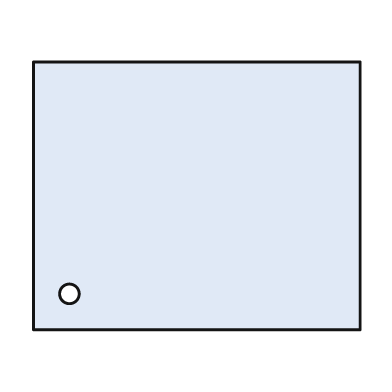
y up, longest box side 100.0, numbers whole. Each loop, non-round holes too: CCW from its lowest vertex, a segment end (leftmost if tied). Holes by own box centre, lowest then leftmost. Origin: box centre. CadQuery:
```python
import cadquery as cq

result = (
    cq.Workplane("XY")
    .moveTo(-50.0, -41.0)
    .lineTo(50.0, -41.0)
    .lineTo(50.0, 41.0)
    .lineTo(-50.0, 41.0)
    .close()
    .moveTo(-39.0, -30.0)
    .circle(3.0)
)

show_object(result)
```